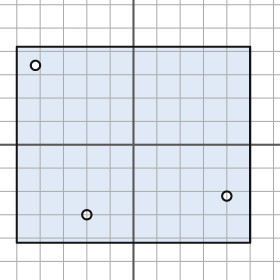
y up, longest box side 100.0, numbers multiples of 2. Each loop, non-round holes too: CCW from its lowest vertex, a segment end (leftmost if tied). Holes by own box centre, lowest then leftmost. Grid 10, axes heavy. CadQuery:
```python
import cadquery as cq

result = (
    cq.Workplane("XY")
    .moveTo(-50.0, -42.0)
    .lineTo(50.0, -42.0)
    .lineTo(50.0, 42.0)
    .lineTo(-50.0, 42.0)
    .close()
    .moveTo(-20.0, -30.0)
    .circle(2.0)
    .moveTo(40.0, -22.0)
    .circle(2.0)
    .moveTo(-42.0, 34.0)
    .circle(2.0)
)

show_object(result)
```